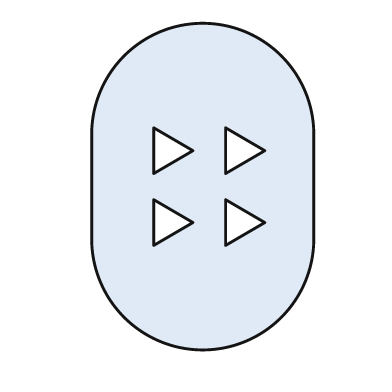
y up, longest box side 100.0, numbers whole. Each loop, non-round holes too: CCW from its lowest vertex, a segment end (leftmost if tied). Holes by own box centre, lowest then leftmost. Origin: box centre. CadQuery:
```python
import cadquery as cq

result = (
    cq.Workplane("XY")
    .moveTo(-34.0, -16.0)
    .threePointArc((0.0, -50.0), (34.0, -16.0))
    .lineTo(34.0, 16.0)
    .threePointArc((0.0, 50.0), (-34.0, 16.0))
    .close()
    .moveTo(-15.0, -18.0)
    .lineTo(-3.0, -11.0)
    .lineTo(-15.0, -4.0)
    .close()
    .moveTo(7.0, -18.0)
    .lineTo(19.0, -11.0)
    .lineTo(7.0, -4.0)
    .close()
    .moveTo(-15.0, 4.0)
    .lineTo(-3.0, 11.0)
    .lineTo(-15.0, 18.0)
    .close()
    .moveTo(7.0, 4.0)
    .lineTo(19.0, 11.0)
    .lineTo(7.0, 18.0)
    .close()
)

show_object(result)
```